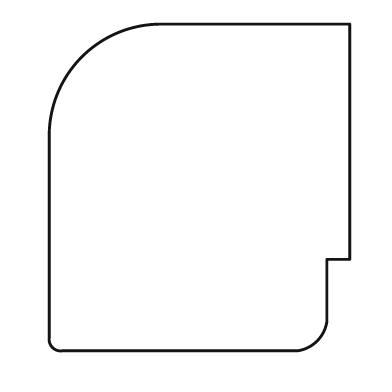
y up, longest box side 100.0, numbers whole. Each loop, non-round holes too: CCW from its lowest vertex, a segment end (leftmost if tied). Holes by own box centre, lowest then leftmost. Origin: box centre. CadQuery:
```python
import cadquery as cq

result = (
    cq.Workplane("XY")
    .moveTo(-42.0, -50.0)
    .lineTo(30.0, -50.0)
    .threePointArc((36.0, -47.0), (39.0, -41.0))
    .lineTo(39.0, -22.0)
    .lineTo(46.0, -22.0)
    .lineTo(46.0, 50.0)
    .lineTo(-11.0, 50.0)
    .threePointArc((-36.0, 40.0), (-46.0, 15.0))
    .lineTo(-46.0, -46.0)
    .threePointArc((-45.0, -49.0), (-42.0, -50.0))
    .close()
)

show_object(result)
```